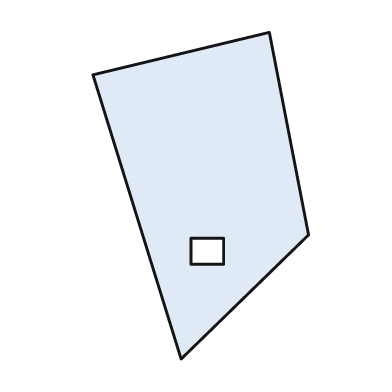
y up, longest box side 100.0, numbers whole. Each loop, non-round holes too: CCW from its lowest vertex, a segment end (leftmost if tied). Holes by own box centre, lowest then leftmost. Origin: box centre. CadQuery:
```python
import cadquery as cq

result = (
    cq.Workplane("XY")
    .moveTo(-6.0, -50.0)
    .lineTo(33.0, -12.0)
    .lineTo(21.0, 50.0)
    .lineTo(-33.0, 37.0)
    .close()
    .moveTo(-3.0, -21.0)
    .lineTo(7.0, -21.0)
    .lineTo(7.0, -13.0)
    .lineTo(-3.0, -13.0)
    .close()
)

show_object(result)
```